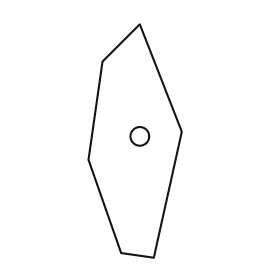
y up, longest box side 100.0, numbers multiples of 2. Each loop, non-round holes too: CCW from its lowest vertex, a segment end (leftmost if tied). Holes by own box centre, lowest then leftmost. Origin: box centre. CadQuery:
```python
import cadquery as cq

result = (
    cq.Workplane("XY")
    .moveTo(8.0, -50.0)
    .lineTo(20.0, 4.0)
    .lineTo(2.0, 50.0)
    .lineTo(-14.0, 34.0)
    .lineTo(-20.0, -8.0)
    .lineTo(-6.0, -48.0)
    .close()
    .moveTo(2.0, 2.0)
    .circle(4.0)
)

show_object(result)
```